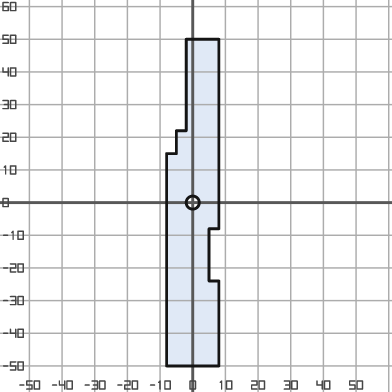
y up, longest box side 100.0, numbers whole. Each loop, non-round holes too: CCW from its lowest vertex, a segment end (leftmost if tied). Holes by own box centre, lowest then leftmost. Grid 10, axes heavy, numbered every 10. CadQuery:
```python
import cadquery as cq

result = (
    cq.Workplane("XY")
    .moveTo(-8.0, -50.0)
    .lineTo(8.0, -50.0)
    .lineTo(8.0, -24.0)
    .lineTo(5.0, -24.0)
    .lineTo(5.0, -8.0)
    .lineTo(8.0, -8.0)
    .lineTo(8.0, 50.0)
    .lineTo(-2.0, 50.0)
    .lineTo(-2.0, 22.0)
    .lineTo(-5.0, 22.0)
    .lineTo(-5.0, 15.0)
    .lineTo(-8.0, 15.0)
    .close()
    .moveTo(0.0, 0.0)
    .circle(2.0)
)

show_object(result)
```